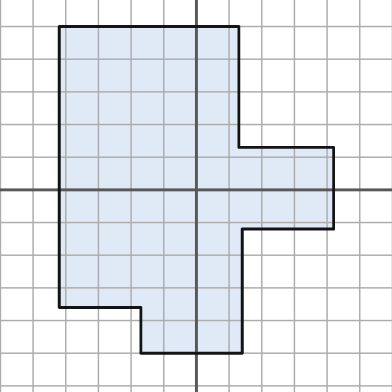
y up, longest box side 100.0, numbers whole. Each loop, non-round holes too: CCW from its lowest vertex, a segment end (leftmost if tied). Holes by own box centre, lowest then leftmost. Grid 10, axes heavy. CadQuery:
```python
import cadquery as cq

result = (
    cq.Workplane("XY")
    .moveTo(-17.0, -50.0)
    .lineTo(14.0, -50.0)
    .lineTo(14.0, -12.0)
    .lineTo(42.0, -12.0)
    .lineTo(42.0, 13.0)
    .lineTo(13.0, 13.0)
    .lineTo(13.0, 50.0)
    .lineTo(-42.0, 50.0)
    .lineTo(-42.0, -36.0)
    .lineTo(-17.0, -36.0)
    .close()
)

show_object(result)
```